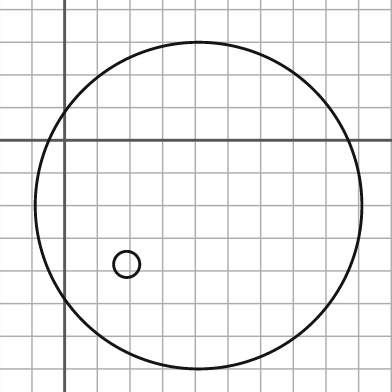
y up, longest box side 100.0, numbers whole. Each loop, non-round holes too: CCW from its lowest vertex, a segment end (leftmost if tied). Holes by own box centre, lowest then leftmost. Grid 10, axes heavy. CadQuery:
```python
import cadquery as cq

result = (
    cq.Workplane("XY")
    .moveTo(41.0, -20.0)
    .circle(50.0)
    .moveTo(19.0, -38.0)
    .circle(4.0)
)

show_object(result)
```